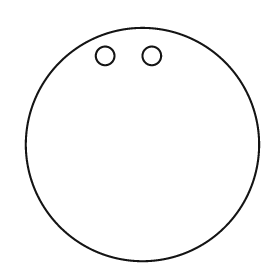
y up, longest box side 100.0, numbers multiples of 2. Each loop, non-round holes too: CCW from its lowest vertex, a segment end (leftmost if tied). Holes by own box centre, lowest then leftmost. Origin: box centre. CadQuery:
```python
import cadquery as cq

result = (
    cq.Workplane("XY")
    .moveTo(0.0, 0.0)
    .circle(50.0)
    .moveTo(-16.0, 38.0)
    .circle(4.0)
    .moveTo(4.0, 38.0)
    .circle(4.0)
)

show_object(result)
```